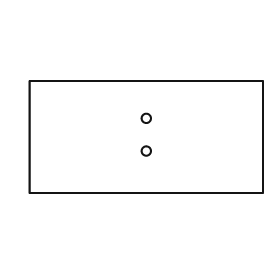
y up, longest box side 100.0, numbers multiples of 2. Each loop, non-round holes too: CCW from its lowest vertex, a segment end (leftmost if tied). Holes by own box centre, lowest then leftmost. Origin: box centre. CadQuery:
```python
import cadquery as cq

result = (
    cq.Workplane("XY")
    .moveTo(-50.0, -24.0)
    .lineTo(50.0, -24.0)
    .lineTo(50.0, 24.0)
    .lineTo(-50.0, 24.0)
    .close()
    .moveTo(0.0, -6.0)
    .circle(2.0)
    .moveTo(0.0, 8.0)
    .circle(2.0)
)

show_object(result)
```